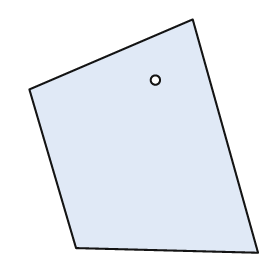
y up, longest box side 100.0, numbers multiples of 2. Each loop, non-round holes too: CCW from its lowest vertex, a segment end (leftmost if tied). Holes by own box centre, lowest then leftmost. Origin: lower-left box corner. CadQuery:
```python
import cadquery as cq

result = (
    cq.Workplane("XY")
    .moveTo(98.0, 0.0)
    .lineTo(70.0, 100.0)
    .lineTo(0.0, 70.0)
    .lineTo(20.0, 2.0)
    .close()
    .moveTo(54.0, 74.0)
    .circle(2.0)
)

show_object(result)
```